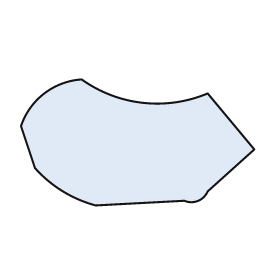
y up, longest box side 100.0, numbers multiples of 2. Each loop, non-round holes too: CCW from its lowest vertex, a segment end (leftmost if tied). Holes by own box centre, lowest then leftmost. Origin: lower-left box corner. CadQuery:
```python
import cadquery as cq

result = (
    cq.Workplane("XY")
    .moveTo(32.0, 0.0)
    .lineTo(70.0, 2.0)
    .threePointArc((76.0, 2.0), (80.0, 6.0))
    .lineTo(100.0, 24.0)
    .lineTo(80.0, 48.0)
    .threePointArc((52.0, 44.0), (26.0, 54.0))
    .threePointArc((10.0, 48.0), (0.0, 34.0))
    .lineTo(6.0, 16.0)
    .threePointArc((18.0, 6.0), (32.0, 0.0))
    .close()
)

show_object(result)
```